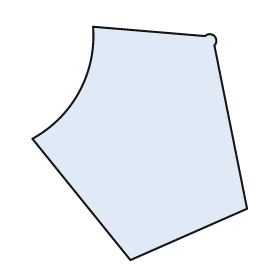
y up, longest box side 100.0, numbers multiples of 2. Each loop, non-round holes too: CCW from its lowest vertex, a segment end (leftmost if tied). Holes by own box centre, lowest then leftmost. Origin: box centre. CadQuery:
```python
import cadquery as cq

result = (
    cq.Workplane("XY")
    .moveTo(-4.0, -50.0)
    .lineTo(46.0, -28.0)
    .lineTo(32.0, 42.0)
    .threePointArc((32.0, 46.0), (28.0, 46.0))
    .lineTo(-20.0, 50.0)
    .threePointArc((-26.0, 22.0), (-46.0, 2.0))
    .close()
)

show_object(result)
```